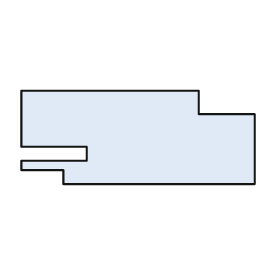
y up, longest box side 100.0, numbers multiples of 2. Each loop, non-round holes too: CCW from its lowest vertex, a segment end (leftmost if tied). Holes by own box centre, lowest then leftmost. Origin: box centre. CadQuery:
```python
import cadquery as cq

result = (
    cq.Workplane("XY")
    .moveTo(-32.0, -20.0)
    .lineTo(50.0, -20.0)
    .lineTo(50.0, 10.0)
    .lineTo(26.0, 10.0)
    .lineTo(26.0, 20.0)
    .lineTo(-50.0, 20.0)
    .lineTo(-50.0, -4.0)
    .lineTo(-22.0, -4.0)
    .lineTo(-22.0, -10.0)
    .lineTo(-50.0, -10.0)
    .lineTo(-50.0, -14.0)
    .lineTo(-32.0, -14.0)
    .close()
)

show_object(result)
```